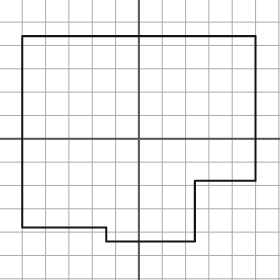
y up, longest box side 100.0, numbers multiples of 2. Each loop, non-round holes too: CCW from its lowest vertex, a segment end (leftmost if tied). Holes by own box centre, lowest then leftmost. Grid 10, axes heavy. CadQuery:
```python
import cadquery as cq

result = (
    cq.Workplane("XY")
    .moveTo(-14.0, -44.0)
    .lineTo(24.0, -44.0)
    .lineTo(24.0, -18.0)
    .lineTo(50.0, -18.0)
    .lineTo(50.0, 44.0)
    .lineTo(-50.0, 44.0)
    .lineTo(-50.0, -38.0)
    .lineTo(-14.0, -38.0)
    .close()
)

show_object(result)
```